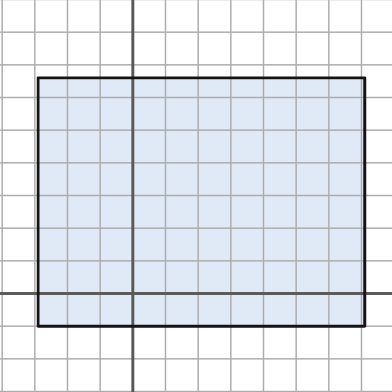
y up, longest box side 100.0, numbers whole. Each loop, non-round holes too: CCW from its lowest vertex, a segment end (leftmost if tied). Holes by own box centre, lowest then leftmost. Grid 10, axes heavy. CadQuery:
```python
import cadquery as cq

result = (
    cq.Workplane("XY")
    .moveTo(-29.0, -10.0)
    .lineTo(71.0, -10.0)
    .lineTo(71.0, 66.0)
    .lineTo(-29.0, 66.0)
    .close()
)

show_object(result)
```